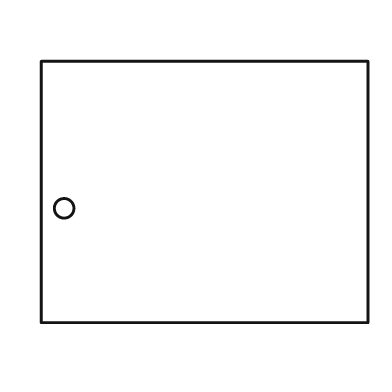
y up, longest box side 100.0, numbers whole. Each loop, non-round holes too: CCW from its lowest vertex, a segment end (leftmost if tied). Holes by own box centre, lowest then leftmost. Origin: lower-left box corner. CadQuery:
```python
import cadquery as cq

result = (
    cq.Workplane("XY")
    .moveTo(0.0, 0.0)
    .lineTo(100.0, 0.0)
    .lineTo(100.0, 80.0)
    .lineTo(0.0, 80.0)
    .close()
    .moveTo(7.0, 35.0)
    .circle(3.0)
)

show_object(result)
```